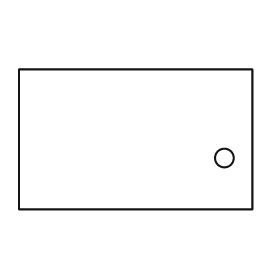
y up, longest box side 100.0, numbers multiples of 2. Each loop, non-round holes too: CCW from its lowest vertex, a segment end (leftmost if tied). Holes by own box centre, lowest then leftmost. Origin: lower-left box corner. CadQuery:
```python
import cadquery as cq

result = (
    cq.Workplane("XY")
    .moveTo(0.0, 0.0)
    .lineTo(100.0, 0.0)
    .lineTo(100.0, 60.0)
    .lineTo(0.0, 60.0)
    .close()
    .moveTo(88.0, 22.0)
    .circle(4.0)
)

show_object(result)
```